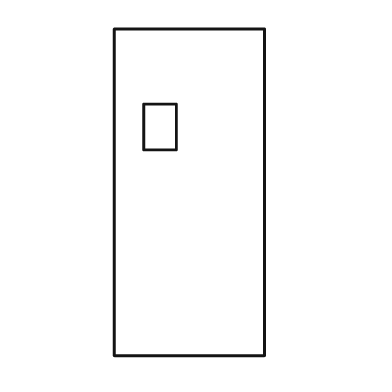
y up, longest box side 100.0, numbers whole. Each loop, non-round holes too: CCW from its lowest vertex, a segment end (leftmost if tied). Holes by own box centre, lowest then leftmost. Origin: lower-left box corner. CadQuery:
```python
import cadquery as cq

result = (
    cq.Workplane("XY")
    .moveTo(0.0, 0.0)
    .lineTo(46.0, 0.0)
    .lineTo(46.0, 100.0)
    .lineTo(0.0, 100.0)
    .close()
    .moveTo(9.0, 63.0)
    .lineTo(19.0, 63.0)
    .lineTo(19.0, 77.0)
    .lineTo(9.0, 77.0)
    .close()
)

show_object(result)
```